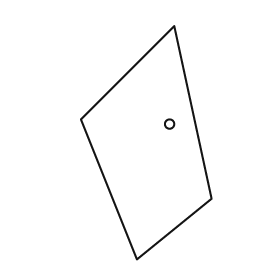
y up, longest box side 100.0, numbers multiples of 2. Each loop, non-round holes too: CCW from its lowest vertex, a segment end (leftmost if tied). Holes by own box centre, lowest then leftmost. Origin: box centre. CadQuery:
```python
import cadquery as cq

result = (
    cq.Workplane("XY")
    .moveTo(-4.0, -50.0)
    .lineTo(28.0, -24.0)
    .lineTo(12.0, 50.0)
    .lineTo(-28.0, 10.0)
    .close()
    .moveTo(10.0, 8.0)
    .circle(2.0)
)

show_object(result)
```